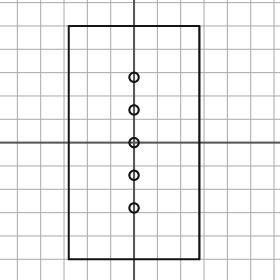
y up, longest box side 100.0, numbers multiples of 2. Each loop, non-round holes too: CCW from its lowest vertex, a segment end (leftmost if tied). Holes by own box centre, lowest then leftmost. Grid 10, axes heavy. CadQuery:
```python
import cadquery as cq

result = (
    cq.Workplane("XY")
    .moveTo(-28.0, -50.0)
    .lineTo(28.0, -50.0)
    .lineTo(28.0, 50.0)
    .lineTo(-28.0, 50.0)
    .close()
    .moveTo(0.0, -28.0)
    .circle(2.0)
    .moveTo(0.0, -14.0)
    .circle(2.0)
    .moveTo(0.0, 0.0)
    .circle(2.0)
    .moveTo(0.0, 14.0)
    .circle(2.0)
    .moveTo(0.0, 28.0)
    .circle(2.0)
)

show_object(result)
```